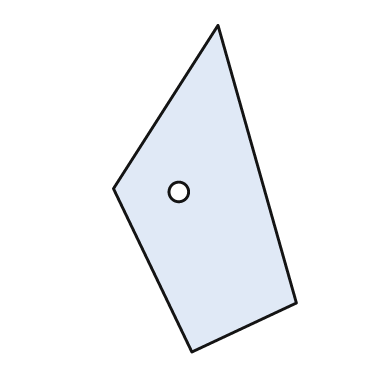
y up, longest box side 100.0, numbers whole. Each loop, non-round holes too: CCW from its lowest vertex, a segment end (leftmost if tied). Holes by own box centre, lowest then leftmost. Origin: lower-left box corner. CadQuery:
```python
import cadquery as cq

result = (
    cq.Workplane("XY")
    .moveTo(24.0, 0.0)
    .lineTo(56.0, 15.0)
    .lineTo(32.0, 100.0)
    .lineTo(0.0, 50.0)
    .close()
    .moveTo(20.0, 49.0)
    .circle(3.0)
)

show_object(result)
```